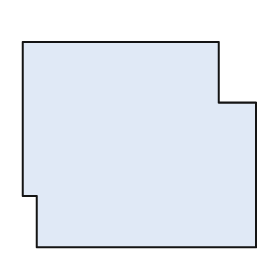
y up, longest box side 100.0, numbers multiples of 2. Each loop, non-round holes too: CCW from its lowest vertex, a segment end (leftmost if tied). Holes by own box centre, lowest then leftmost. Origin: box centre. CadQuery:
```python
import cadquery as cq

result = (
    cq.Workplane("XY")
    .moveTo(-44.0, -44.0)
    .lineTo(50.0, -44.0)
    .lineTo(50.0, 18.0)
    .lineTo(34.0, 18.0)
    .lineTo(34.0, 44.0)
    .lineTo(-50.0, 44.0)
    .lineTo(-50.0, -22.0)
    .lineTo(-44.0, -22.0)
    .close()
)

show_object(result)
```